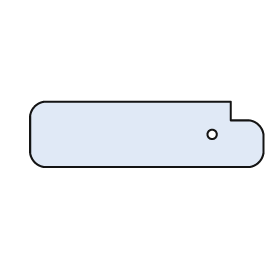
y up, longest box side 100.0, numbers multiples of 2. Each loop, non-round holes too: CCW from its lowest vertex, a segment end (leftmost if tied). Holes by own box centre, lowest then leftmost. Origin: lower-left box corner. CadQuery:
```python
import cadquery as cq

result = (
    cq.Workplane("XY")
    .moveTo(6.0, 0.0)
    .lineTo(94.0, 0.0)
    .threePointArc((98.0, 2.0), (100.0, 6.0))
    .lineTo(100.0, 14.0)
    .threePointArc((98.0, 18.0), (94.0, 20.0))
    .lineTo(86.0, 20.0)
    .lineTo(86.0, 28.0)
    .lineTo(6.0, 28.0)
    .threePointArc((2.0, 26.0), (0.0, 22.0))
    .lineTo(0.0, 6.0)
    .threePointArc((2.0, 2.0), (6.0, 0.0))
    .close()
    .moveTo(78.0, 14.0)
    .circle(2.0)
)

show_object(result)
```